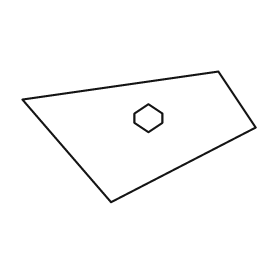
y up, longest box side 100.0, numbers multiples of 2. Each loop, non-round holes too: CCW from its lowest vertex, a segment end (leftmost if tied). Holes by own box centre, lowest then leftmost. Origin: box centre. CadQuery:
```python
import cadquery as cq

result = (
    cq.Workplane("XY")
    .moveTo(-12.0, -28.0)
    .lineTo(50.0, 4.0)
    .lineTo(34.0, 28.0)
    .lineTo(-50.0, 16.0)
    .close()
    .moveTo(4.0, 2.0)
    .lineTo(10.0, 6.0)
    .lineTo(10.0, 10.0)
    .lineTo(4.0, 14.0)
    .lineTo(-2.0, 10.0)
    .lineTo(-2.0, 6.0)
    .close()
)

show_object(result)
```